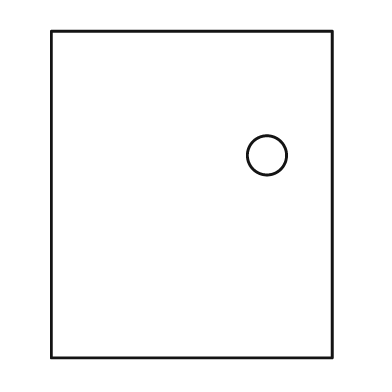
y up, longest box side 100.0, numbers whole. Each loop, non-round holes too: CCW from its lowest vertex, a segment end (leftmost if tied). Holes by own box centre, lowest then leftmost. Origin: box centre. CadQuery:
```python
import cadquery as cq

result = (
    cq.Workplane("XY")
    .moveTo(-43.0, -50.0)
    .lineTo(43.0, -50.0)
    .lineTo(43.0, 50.0)
    .lineTo(-43.0, 50.0)
    .close()
    .moveTo(23.0, 12.0)
    .circle(6.0)
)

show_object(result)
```